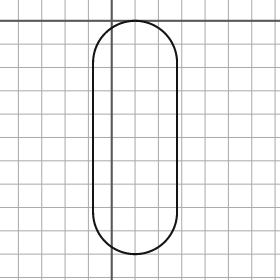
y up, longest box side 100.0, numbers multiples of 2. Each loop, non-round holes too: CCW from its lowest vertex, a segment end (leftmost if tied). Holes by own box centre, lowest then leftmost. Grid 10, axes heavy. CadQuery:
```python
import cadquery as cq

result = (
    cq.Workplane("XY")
    .moveTo(-8.0, -82.0)
    .threePointArc((10.0, -100.0), (28.0, -82.0))
    .lineTo(28.0, -18.0)
    .threePointArc((10.0, 0.0), (-8.0, -18.0))
    .close()
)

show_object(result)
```